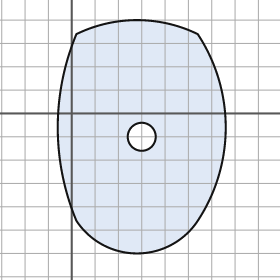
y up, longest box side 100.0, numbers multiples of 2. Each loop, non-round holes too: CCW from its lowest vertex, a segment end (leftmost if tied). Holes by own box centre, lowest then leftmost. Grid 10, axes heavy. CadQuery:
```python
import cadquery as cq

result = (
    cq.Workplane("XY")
    .moveTo(2.0, -46.0)
    .threePointArc((28.0, -60.0), (54.0, -46.0))
    .threePointArc((66.0, -6.0), (54.0, 34.0))
    .threePointArc((28.0, 40.0), (2.0, 34.0))
    .threePointArc((-6.0, -6.0), (2.0, -46.0))
    .close()
    .moveTo(30.0, -10.0)
    .circle(6.0)
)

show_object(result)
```